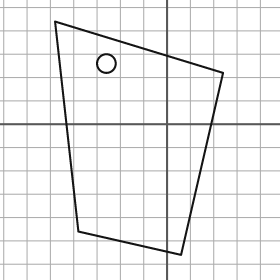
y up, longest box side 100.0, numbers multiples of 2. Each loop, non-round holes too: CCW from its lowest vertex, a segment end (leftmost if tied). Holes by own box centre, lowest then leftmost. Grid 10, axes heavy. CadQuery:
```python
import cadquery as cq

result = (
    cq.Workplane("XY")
    .moveTo(6.0, -56.0)
    .lineTo(24.0, 22.0)
    .lineTo(-48.0, 44.0)
    .lineTo(-38.0, -46.0)
    .close()
    .moveTo(-26.0, 26.0)
    .circle(4.0)
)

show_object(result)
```